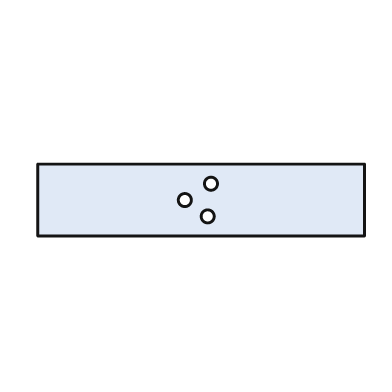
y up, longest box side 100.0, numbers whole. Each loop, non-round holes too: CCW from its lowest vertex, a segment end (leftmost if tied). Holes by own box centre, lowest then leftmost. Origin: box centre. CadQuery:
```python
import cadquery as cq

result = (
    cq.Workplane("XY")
    .moveTo(-50.0, -11.0)
    .lineTo(50.0, -11.0)
    .lineTo(50.0, 11.0)
    .lineTo(-50.0, 11.0)
    .close()
    .moveTo(2.0, -5.0)
    .circle(2.0)
    .moveTo(-5.0, 0.0)
    .circle(2.0)
    .moveTo(3.0, 5.0)
    .circle(2.0)
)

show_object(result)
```